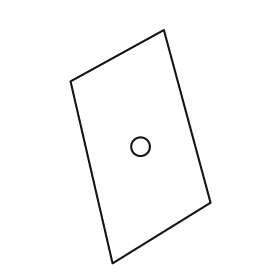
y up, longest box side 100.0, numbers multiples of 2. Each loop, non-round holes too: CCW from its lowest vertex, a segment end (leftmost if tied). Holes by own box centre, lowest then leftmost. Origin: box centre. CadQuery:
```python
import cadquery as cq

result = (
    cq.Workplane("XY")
    .moveTo(-12.0, -50.0)
    .lineTo(30.0, -24.0)
    .lineTo(10.0, 50.0)
    .lineTo(-30.0, 28.0)
    .close()
    .moveTo(0.0, 0.0)
    .circle(4.0)
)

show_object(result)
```